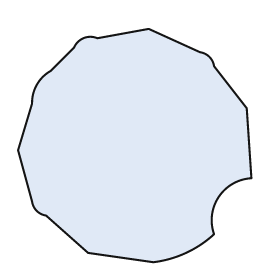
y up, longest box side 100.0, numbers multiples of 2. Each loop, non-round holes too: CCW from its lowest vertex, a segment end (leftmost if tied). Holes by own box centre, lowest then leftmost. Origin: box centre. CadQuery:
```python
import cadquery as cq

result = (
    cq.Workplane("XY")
    .moveTo(8.0, -50.0)
    .threePointArc((22.0, -46.0), (34.0, -38.0))
    .threePointArc((36.0, -22.0), (50.0, -14.0))
    .lineTo(48.0, 16.0)
    .lineTo(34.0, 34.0)
    .threePointArc((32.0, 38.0), (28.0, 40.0))
    .lineTo(6.0, 50.0)
    .lineTo(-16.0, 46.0)
    .threePointArc((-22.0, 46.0), (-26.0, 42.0))
    .lineTo(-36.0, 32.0)
    .threePointArc((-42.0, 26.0), (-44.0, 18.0))
    .lineTo(-50.0, -2.0)
    .lineTo(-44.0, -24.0)
    .threePointArc((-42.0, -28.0), (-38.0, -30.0))
    .lineTo(-20.0, -46.0)
    .close()
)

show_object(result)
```